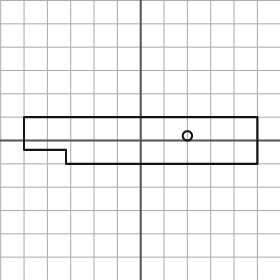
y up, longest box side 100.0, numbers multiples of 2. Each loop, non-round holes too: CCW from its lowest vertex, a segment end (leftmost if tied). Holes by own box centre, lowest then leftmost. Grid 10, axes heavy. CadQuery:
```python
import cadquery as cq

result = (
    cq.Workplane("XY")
    .moveTo(-32.0, -10.0)
    .lineTo(50.0, -10.0)
    .lineTo(50.0, 10.0)
    .lineTo(-50.0, 10.0)
    .lineTo(-50.0, -4.0)
    .lineTo(-32.0, -4.0)
    .close()
    .moveTo(20.0, 2.0)
    .circle(2.0)
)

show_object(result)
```